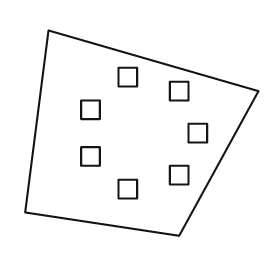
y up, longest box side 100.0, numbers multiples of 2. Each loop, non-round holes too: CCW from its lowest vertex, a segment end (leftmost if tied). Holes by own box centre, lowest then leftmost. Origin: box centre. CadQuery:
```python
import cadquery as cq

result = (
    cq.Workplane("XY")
    .moveTo(16.0, -44.0)
    .lineTo(50.0, 18.0)
    .lineTo(-40.0, 44.0)
    .lineTo(-50.0, -34.0)
    .close()
    .moveTo(-10.0, -28.0)
    .lineTo(-2.0, -28.0)
    .lineTo(-2.0, -20.0)
    .lineTo(-10.0, -20.0)
    .close()
    .moveTo(12.0, -22.0)
    .lineTo(20.0, -22.0)
    .lineTo(20.0, -14.0)
    .lineTo(12.0, -14.0)
    .close()
    .moveTo(-26.0, -14.0)
    .lineTo(-18.0, -14.0)
    .lineTo(-18.0, -6.0)
    .lineTo(-26.0, -6.0)
    .close()
    .moveTo(20.0, -4.0)
    .lineTo(28.0, -4.0)
    .lineTo(28.0, 4.0)
    .lineTo(20.0, 4.0)
    .close()
    .moveTo(-26.0, 6.0)
    .lineTo(-18.0, 6.0)
    .lineTo(-18.0, 14.0)
    .lineTo(-26.0, 14.0)
    .close()
    .moveTo(12.0, 14.0)
    .lineTo(20.0, 14.0)
    .lineTo(20.0, 22.0)
    .lineTo(12.0, 22.0)
    .close()
    .moveTo(-10.0, 20.0)
    .lineTo(-2.0, 20.0)
    .lineTo(-2.0, 28.0)
    .lineTo(-10.0, 28.0)
    .close()
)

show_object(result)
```